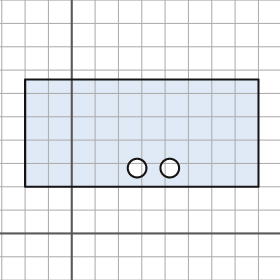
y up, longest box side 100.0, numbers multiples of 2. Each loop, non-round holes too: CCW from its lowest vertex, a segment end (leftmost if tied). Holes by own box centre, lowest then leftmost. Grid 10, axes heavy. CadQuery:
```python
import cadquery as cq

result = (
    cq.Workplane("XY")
    .moveTo(-20.0, 20.0)
    .lineTo(80.0, 20.0)
    .lineTo(80.0, 66.0)
    .lineTo(-20.0, 66.0)
    .close()
    .moveTo(28.0, 28.0)
    .circle(4.0)
    .moveTo(42.0, 28.0)
    .circle(4.0)
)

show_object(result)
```